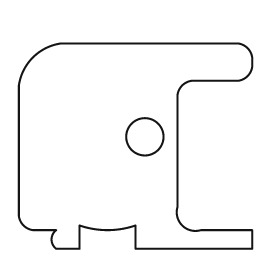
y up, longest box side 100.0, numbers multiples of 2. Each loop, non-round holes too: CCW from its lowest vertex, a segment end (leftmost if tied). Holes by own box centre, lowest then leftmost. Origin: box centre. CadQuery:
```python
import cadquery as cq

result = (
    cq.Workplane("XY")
    .moveTo(-34.0, -44.0)
    .lineTo(-24.0, -44.0)
    .lineTo(-24.0, -34.0)
    .threePointArc((-12.0, -36.0), (0.0, -34.0))
    .lineTo(0.0, -44.0)
    .lineTo(50.0, -44.0)
    .lineTo(50.0, -36.0)
    .lineTo(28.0, -36.0)
    .threePointArc((20.0, -34.0), (18.0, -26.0))
    .lineTo(18.0, 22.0)
    .threePointArc((20.0, 26.0), (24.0, 28.0))
    .lineTo(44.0, 28.0)
    .threePointArc((48.0, 30.0), (50.0, 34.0))
    .lineTo(50.0, 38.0)
    .threePointArc((48.0, 42.0), (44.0, 44.0))
    .lineTo(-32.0, 44.0)
    .threePointArc((-44.0, 38.0), (-50.0, 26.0))
    .lineTo(-50.0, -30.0)
    .threePointArc((-48.0, -34.0), (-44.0, -36.0))
    .lineTo(-34.0, -36.0)
    .threePointArc((-36.0, -40.0), (-34.0, -44.0))
    .close()
    .moveTo(4.0, 4.0)
    .circle(8.0)
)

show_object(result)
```